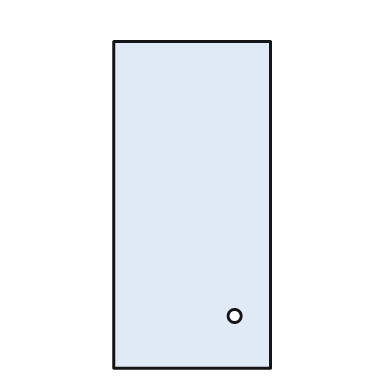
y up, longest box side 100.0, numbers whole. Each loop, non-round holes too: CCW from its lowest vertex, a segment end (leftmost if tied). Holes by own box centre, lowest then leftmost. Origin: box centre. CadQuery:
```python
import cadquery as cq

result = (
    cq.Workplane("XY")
    .moveTo(-24.0, -50.0)
    .lineTo(24.0, -50.0)
    .lineTo(24.0, 50.0)
    .lineTo(-24.0, 50.0)
    .close()
    .moveTo(13.0, -34.0)
    .circle(2.0)
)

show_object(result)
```